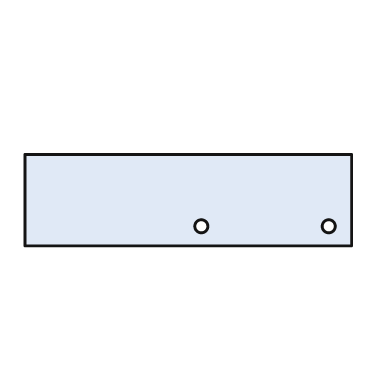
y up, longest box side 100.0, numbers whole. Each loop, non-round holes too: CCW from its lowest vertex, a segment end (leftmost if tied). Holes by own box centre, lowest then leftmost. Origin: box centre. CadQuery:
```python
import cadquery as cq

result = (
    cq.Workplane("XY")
    .moveTo(-50.0, -14.0)
    .lineTo(50.0, -14.0)
    .lineTo(50.0, 14.0)
    .lineTo(-50.0, 14.0)
    .close()
    .moveTo(4.0, -8.0)
    .circle(2.0)
    .moveTo(43.0, -8.0)
    .circle(2.0)
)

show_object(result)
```